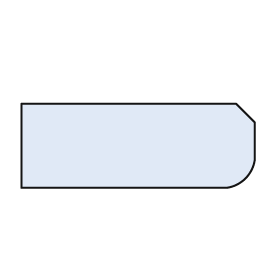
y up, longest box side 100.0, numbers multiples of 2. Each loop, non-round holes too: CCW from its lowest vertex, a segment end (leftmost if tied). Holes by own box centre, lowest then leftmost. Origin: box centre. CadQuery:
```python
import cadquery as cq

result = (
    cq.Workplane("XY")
    .moveTo(-50.0, -18.0)
    .lineTo(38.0, -18.0)
    .threePointArc((46.0, -14.0), (50.0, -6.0))
    .lineTo(50.0, 10.0)
    .lineTo(42.0, 18.0)
    .lineTo(-50.0, 18.0)
    .close()
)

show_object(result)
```